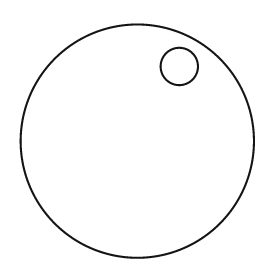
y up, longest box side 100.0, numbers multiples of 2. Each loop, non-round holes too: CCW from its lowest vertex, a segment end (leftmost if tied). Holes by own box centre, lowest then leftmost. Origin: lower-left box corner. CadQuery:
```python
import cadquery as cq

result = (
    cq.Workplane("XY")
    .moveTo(50.0, 50.0)
    .circle(50.0)
    .moveTo(68.0, 82.0)
    .circle(8.0)
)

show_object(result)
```